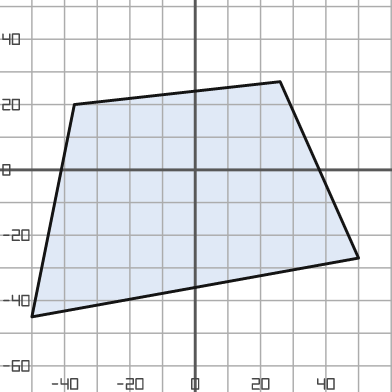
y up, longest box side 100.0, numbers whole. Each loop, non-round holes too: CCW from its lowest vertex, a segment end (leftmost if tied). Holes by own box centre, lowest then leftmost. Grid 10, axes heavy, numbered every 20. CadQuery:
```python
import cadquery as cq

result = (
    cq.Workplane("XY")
    .moveTo(-50.0, -45.0)
    .lineTo(50.0, -27.0)
    .lineTo(26.0, 27.0)
    .lineTo(-37.0, 20.0)
    .close()
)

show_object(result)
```